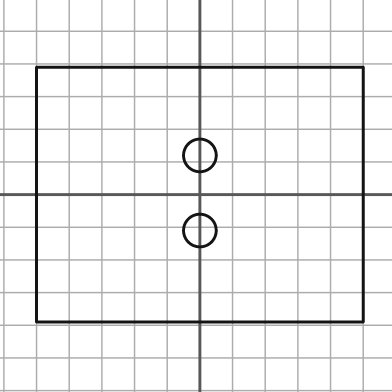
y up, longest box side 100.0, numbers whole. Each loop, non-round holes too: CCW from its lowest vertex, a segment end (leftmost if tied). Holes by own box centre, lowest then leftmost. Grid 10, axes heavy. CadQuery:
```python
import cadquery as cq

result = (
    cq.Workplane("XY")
    .moveTo(-50.0, -39.0)
    .lineTo(50.0, -39.0)
    .lineTo(50.0, 39.0)
    .lineTo(-50.0, 39.0)
    .close()
    .moveTo(0.0, -11.0)
    .circle(5.0)
    .moveTo(0.0, 12.0)
    .circle(5.0)
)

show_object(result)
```